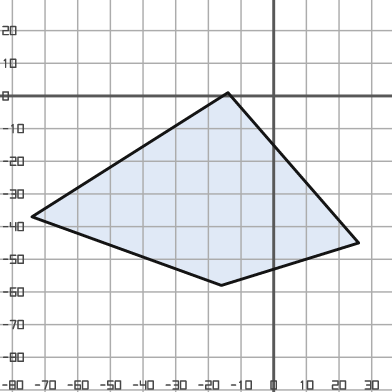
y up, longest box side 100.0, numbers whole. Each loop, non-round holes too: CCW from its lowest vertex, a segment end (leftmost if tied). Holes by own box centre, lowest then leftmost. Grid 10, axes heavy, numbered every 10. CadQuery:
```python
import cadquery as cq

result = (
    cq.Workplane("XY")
    .moveTo(-16.0, -58.0)
    .lineTo(26.0, -45.0)
    .lineTo(-14.0, 1.0)
    .lineTo(-74.0, -37.0)
    .close()
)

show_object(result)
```